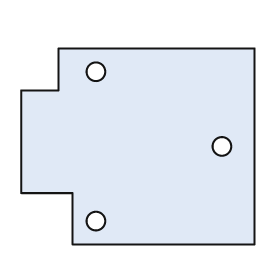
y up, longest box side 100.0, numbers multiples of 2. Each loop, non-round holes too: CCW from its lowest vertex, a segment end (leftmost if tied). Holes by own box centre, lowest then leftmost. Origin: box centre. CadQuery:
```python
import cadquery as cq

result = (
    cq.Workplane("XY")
    .moveTo(-28.0, -42.0)
    .lineTo(50.0, -42.0)
    .lineTo(50.0, 42.0)
    .lineTo(-34.0, 42.0)
    .lineTo(-34.0, 24.0)
    .lineTo(-50.0, 24.0)
    .lineTo(-50.0, -20.0)
    .lineTo(-28.0, -20.0)
    .close()
    .moveTo(-18.0, -32.0)
    .circle(4.0)
    .moveTo(36.0, 0.0)
    .circle(4.0)
    .moveTo(-18.0, 32.0)
    .circle(4.0)
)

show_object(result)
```